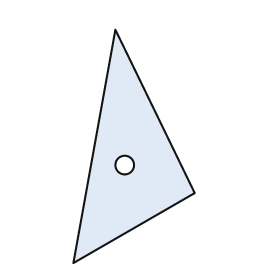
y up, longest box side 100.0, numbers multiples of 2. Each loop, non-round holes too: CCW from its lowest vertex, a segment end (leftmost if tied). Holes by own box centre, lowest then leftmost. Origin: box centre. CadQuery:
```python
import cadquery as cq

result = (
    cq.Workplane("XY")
    .moveTo(-26.0, -50.0)
    .lineTo(26.0, -20.0)
    .lineTo(-8.0, 50.0)
    .close()
    .moveTo(-4.0, -8.0)
    .circle(4.0)
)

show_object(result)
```